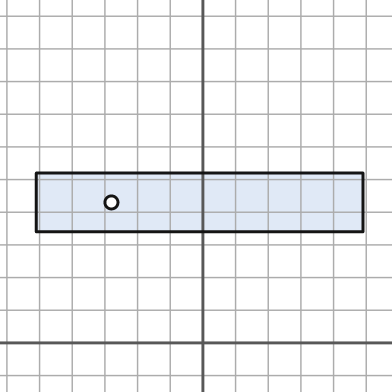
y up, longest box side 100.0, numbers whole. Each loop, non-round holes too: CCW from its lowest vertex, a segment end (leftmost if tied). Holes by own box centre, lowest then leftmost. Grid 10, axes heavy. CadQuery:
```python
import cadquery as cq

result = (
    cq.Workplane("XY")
    .moveTo(-51.0, 34.0)
    .lineTo(49.0, 34.0)
    .lineTo(49.0, 52.0)
    .lineTo(-51.0, 52.0)
    .close()
    .moveTo(-28.0, 43.0)
    .circle(2.0)
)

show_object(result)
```